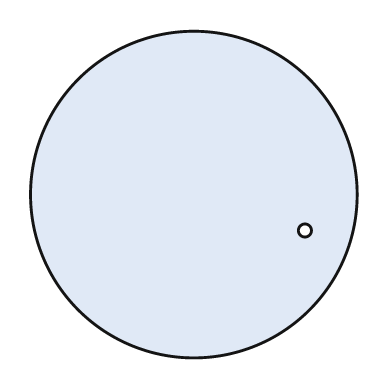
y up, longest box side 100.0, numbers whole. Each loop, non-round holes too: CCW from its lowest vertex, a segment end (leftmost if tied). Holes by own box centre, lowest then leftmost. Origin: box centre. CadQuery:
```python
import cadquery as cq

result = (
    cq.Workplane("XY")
    .moveTo(0.0, 0.0)
    .circle(50.0)
    .moveTo(34.0, -11.0)
    .circle(2.0)
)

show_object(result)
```